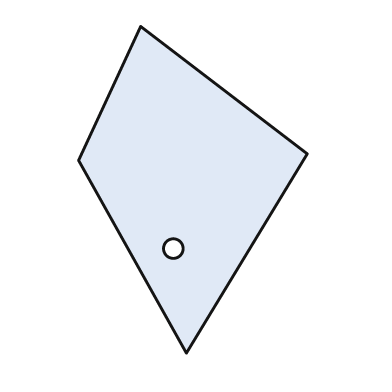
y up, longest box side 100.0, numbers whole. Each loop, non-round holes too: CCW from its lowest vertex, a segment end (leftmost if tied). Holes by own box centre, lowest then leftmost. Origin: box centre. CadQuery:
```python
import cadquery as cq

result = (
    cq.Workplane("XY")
    .moveTo(-2.0, -50.0)
    .lineTo(35.0, 11.0)
    .lineTo(-16.0, 50.0)
    .lineTo(-35.0, 9.0)
    .close()
    .moveTo(-6.0, -18.0)
    .circle(3.0)
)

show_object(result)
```